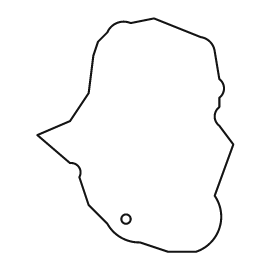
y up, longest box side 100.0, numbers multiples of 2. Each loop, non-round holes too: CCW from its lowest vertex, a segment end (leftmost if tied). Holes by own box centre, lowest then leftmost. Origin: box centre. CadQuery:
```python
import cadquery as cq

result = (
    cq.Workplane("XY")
    .moveTo(14.0, -50.0)
    .lineTo(26.0, -50.0)
    .threePointArc((36.0, -40.0), (34.0, -26.0))
    .lineTo(42.0, -4.0)
    .lineTo(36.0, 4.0)
    .threePointArc((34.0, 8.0), (36.0, 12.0))
    .lineTo(36.0, 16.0)
    .threePointArc((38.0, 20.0), (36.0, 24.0))
    .lineTo(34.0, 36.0)
    .threePointArc((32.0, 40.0), (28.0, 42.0))
    .lineTo(8.0, 50.0)
    .lineTo(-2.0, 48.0)
    .threePointArc((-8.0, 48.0), (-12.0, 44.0))
    .lineTo(-16.0, 40.0)
    .lineTo(-18.0, 34.0)
    .lineTo(-20.0, 18.0)
    .lineTo(-28.0, 6.0)
    .lineTo(-42.0, 0.0)
    .lineTo(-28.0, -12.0)
    .threePointArc((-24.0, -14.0), (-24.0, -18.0))
    .lineTo(-20.0, -30.0)
    .lineTo(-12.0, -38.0)
    .threePointArc((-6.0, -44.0), (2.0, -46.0))
    .close()
    .moveTo(-4.0, -36.0)
    .circle(2.0)
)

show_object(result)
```